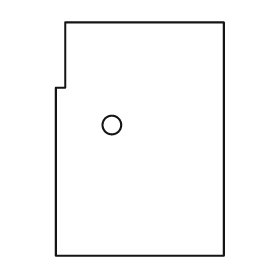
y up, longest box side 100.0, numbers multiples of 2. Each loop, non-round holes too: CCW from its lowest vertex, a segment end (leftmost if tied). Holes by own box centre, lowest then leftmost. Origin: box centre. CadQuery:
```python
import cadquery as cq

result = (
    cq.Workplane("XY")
    .moveTo(-36.0, -50.0)
    .lineTo(36.0, -50.0)
    .lineTo(36.0, 50.0)
    .lineTo(-32.0, 50.0)
    .lineTo(-32.0, 22.0)
    .lineTo(-36.0, 22.0)
    .close()
    .moveTo(-12.0, 6.0)
    .circle(4.0)
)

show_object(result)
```